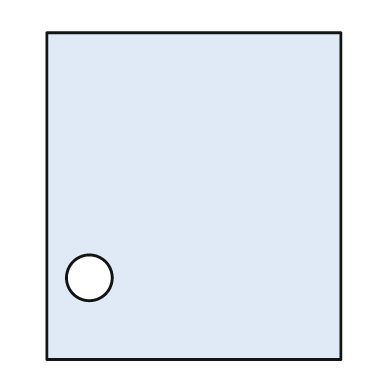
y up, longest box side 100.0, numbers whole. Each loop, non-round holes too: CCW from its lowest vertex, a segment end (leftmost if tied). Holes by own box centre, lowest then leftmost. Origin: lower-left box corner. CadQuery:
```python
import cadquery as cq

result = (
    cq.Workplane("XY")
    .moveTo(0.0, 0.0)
    .lineTo(90.0, 0.0)
    .lineTo(90.0, 100.0)
    .lineTo(0.0, 100.0)
    .close()
    .moveTo(13.0, 25.0)
    .circle(7.0)
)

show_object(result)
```